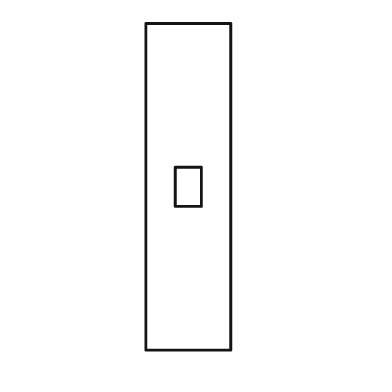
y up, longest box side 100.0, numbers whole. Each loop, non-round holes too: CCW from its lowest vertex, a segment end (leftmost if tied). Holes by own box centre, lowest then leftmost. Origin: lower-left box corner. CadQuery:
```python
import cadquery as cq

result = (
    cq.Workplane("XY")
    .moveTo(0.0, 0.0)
    .lineTo(26.0, 0.0)
    .lineTo(26.0, 100.0)
    .lineTo(0.0, 100.0)
    .close()
    .moveTo(9.0, 44.0)
    .lineTo(17.0, 44.0)
    .lineTo(17.0, 56.0)
    .lineTo(9.0, 56.0)
    .close()
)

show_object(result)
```